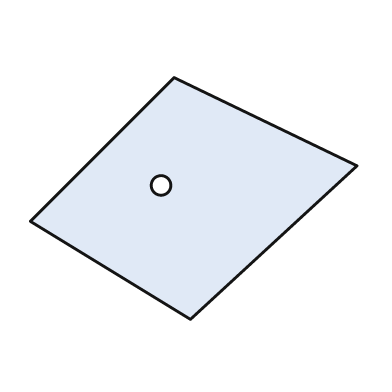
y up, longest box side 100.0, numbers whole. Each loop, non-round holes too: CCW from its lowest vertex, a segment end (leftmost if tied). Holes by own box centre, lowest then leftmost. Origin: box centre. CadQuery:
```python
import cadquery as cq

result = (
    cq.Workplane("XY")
    .moveTo(-1.0, -37.0)
    .lineTo(50.0, 10.0)
    .lineTo(-6.0, 37.0)
    .lineTo(-50.0, -7.0)
    .close()
    .moveTo(-10.0, 4.0)
    .circle(3.0)
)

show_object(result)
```